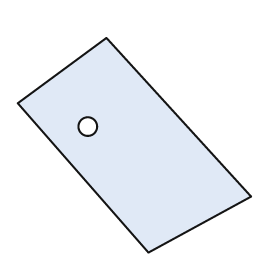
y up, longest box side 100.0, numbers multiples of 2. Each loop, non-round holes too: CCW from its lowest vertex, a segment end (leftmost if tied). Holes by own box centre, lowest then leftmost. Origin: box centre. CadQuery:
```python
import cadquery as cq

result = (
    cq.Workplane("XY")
    .moveTo(6.0, -46.0)
    .lineTo(50.0, -22.0)
    .lineTo(-12.0, 46.0)
    .lineTo(-50.0, 18.0)
    .close()
    .moveTo(-20.0, 8.0)
    .circle(4.0)
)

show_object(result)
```